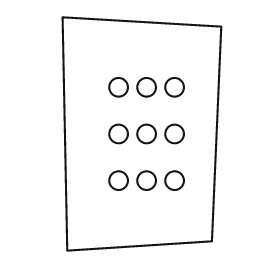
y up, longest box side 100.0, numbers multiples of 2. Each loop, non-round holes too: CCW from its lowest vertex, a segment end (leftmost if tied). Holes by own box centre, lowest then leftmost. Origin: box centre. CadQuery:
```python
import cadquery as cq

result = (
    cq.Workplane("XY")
    .moveTo(-32.0, -50.0)
    .lineTo(30.0, -46.0)
    .lineTo(34.0, 46.0)
    .lineTo(-34.0, 50.0)
    .close()
    .moveTo(-10.0, -20.0)
    .circle(4.0)
    .moveTo(2.0, -20.0)
    .circle(4.0)
    .moveTo(14.0, -20.0)
    .circle(4.0)
    .moveTo(-10.0, 0.0)
    .circle(4.0)
    .moveTo(2.0, 0.0)
    .circle(4.0)
    .moveTo(14.0, 0.0)
    .circle(4.0)
    .moveTo(-10.0, 20.0)
    .circle(4.0)
    .moveTo(2.0, 20.0)
    .circle(4.0)
    .moveTo(14.0, 20.0)
    .circle(4.0)
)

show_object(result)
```